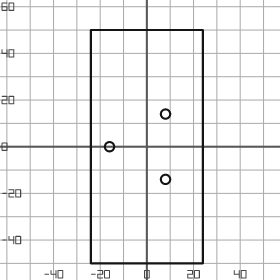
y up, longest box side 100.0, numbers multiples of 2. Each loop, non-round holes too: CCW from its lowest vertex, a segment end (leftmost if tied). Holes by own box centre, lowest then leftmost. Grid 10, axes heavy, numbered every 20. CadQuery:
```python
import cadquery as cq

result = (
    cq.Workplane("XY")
    .moveTo(-24.0, -50.0)
    .lineTo(24.0, -50.0)
    .lineTo(24.0, 50.0)
    .lineTo(-24.0, 50.0)
    .close()
    .moveTo(8.0, -14.0)
    .circle(2.0)
    .moveTo(-16.0, 0.0)
    .circle(2.0)
    .moveTo(8.0, 14.0)
    .circle(2.0)
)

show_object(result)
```